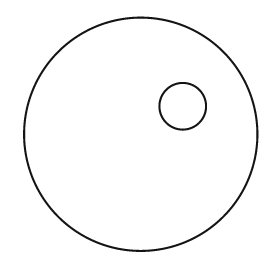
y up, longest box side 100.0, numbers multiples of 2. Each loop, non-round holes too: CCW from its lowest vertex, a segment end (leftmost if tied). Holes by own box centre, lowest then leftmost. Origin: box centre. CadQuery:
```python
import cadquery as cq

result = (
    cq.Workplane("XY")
    .moveTo(0.0, 0.0)
    .circle(50.0)
    .moveTo(18.0, 12.0)
    .circle(10.0)
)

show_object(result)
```